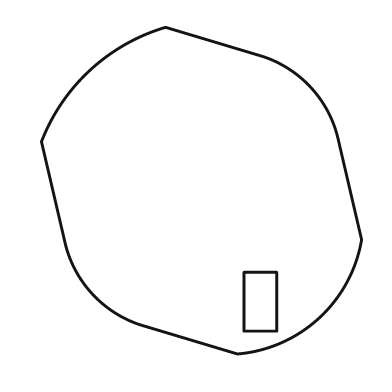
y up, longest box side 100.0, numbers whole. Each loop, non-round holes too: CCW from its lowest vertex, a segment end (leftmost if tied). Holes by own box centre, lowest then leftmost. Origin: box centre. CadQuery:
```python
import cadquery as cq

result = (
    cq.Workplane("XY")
    .moveTo(11.0, -50.0)
    .threePointArc((36.0, -39.0), (49.0, -15.0))
    .lineTo(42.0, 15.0)
    .threePointArc((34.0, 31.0), (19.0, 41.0))
    .lineTo(-11.0, 50.0)
    .threePointArc((-34.0, 37.0), (-49.0, 15.0))
    .lineTo(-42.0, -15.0)
    .threePointArc((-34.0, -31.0), (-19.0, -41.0))
    .close()
    .moveTo(13.0, -43.0)
    .lineTo(23.0, -43.0)
    .lineTo(23.0, -25.0)
    .lineTo(13.0, -25.0)
    .close()
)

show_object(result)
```